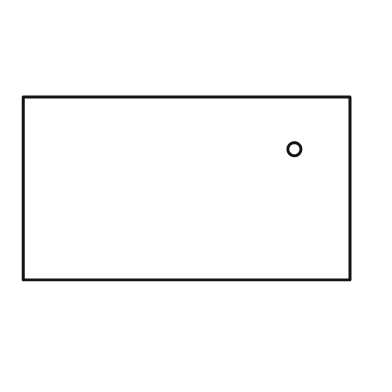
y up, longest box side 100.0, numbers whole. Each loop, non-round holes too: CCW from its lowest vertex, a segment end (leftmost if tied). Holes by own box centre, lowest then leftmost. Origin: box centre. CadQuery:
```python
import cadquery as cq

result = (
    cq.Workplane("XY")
    .moveTo(-50.0, -28.0)
    .lineTo(50.0, -28.0)
    .lineTo(50.0, 28.0)
    .lineTo(-50.0, 28.0)
    .close()
    .moveTo(33.0, 12.0)
    .circle(2.0)
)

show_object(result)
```